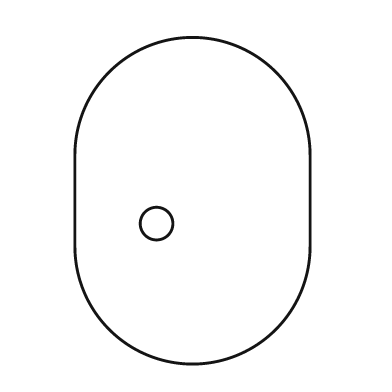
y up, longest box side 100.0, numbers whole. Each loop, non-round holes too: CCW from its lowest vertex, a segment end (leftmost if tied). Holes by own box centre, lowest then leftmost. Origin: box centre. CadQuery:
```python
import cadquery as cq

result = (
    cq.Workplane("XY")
    .moveTo(-36.0, -14.0)
    .threePointArc((0.0, -50.0), (36.0, -14.0))
    .lineTo(36.0, 14.0)
    .threePointArc((0.0, 50.0), (-36.0, 14.0))
    .close()
    .moveTo(-11.0, -7.0)
    .circle(5.0)
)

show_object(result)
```